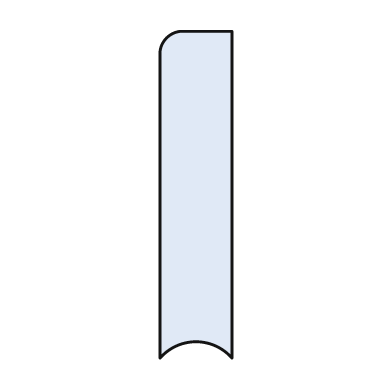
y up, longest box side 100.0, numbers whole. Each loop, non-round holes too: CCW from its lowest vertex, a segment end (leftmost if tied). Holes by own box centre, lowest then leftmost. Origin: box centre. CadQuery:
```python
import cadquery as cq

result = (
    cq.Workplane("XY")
    .moveTo(-11.0, -50.0)
    .threePointArc((0.0, -45.0), (11.0, -50.0))
    .lineTo(11.0, 50.0)
    .lineTo(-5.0, 50.0)
    .threePointArc((-9.0, 48.0), (-11.0, 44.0))
    .close()
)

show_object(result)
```